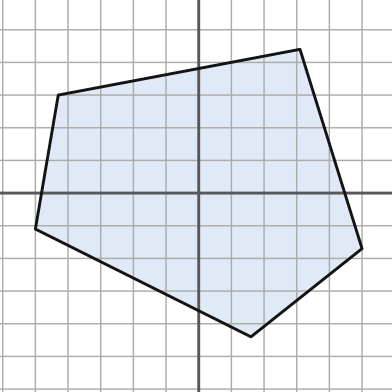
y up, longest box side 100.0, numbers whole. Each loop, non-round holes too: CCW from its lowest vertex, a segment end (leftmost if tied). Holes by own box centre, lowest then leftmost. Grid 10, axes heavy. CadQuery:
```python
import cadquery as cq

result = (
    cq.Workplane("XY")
    .moveTo(16.0, -44.0)
    .lineTo(50.0, -17.0)
    .lineTo(31.0, 44.0)
    .lineTo(-43.0, 30.0)
    .lineTo(-50.0, -11.0)
    .close()
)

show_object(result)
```